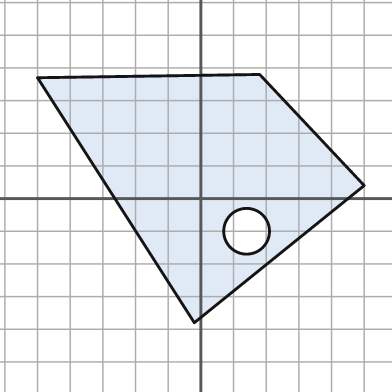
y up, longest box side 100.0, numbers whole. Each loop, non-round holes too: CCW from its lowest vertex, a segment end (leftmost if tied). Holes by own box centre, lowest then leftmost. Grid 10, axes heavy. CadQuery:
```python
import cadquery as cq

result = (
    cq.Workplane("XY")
    .moveTo(-2.0, -38.0)
    .lineTo(50.0, 4.0)
    .lineTo(18.0, 38.0)
    .lineTo(-50.0, 37.0)
    .close()
    .moveTo(14.0, -10.0)
    .circle(7.0)
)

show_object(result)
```